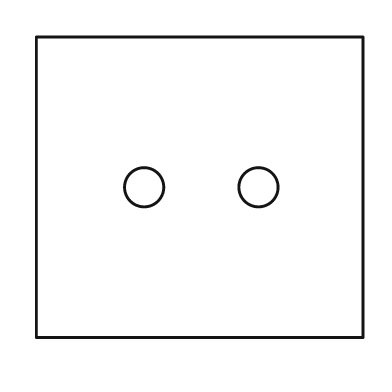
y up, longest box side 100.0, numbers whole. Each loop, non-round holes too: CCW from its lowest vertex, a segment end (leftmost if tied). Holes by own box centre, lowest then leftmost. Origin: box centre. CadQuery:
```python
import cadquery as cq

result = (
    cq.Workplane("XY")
    .moveTo(-50.0, -46.0)
    .lineTo(50.0, -46.0)
    .lineTo(50.0, 46.0)
    .lineTo(-50.0, 46.0)
    .close()
    .moveTo(-17.0, 0.0)
    .circle(6.0)
    .moveTo(18.0, 0.0)
    .circle(6.0)
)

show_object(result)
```